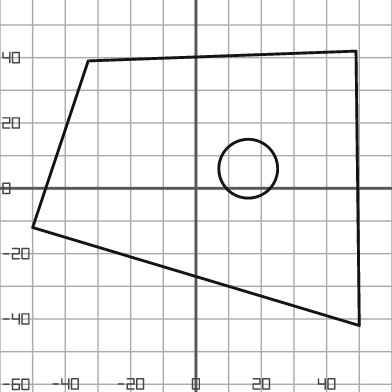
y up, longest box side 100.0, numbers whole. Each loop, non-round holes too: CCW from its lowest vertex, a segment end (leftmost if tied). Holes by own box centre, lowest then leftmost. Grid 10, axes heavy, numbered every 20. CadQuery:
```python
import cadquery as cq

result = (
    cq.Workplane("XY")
    .moveTo(50.0, -42.0)
    .lineTo(49.0, 42.0)
    .lineTo(-33.0, 39.0)
    .lineTo(-50.0, -12.0)
    .close()
    .moveTo(16.0, 6.0)
    .circle(9.0)
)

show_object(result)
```